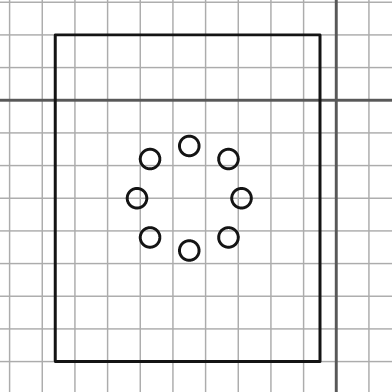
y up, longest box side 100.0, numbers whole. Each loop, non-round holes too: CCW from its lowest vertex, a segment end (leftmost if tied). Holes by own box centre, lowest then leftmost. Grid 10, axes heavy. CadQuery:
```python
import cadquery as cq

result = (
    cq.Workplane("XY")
    .moveTo(-86.0, -80.0)
    .lineTo(-5.0, -80.0)
    .lineTo(-5.0, 20.0)
    .lineTo(-86.0, 20.0)
    .close()
    .moveTo(-45.0, -46.0)
    .circle(3.0)
    .moveTo(-57.0, -42.0)
    .circle(3.0)
    .moveTo(-33.0, -42.0)
    .circle(3.0)
    .moveTo(-61.0, -30.0)
    .circle(3.0)
    .moveTo(-29.0, -30.0)
    .circle(3.0)
    .moveTo(-57.0, -18.0)
    .circle(3.0)
    .moveTo(-33.0, -18.0)
    .circle(3.0)
    .moveTo(-45.0, -14.0)
    .circle(3.0)
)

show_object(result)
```